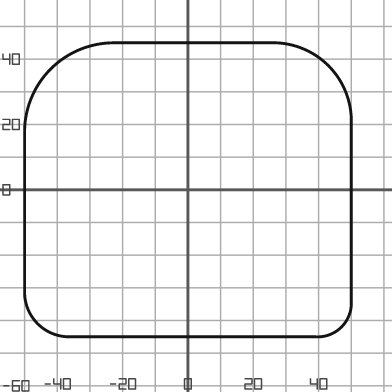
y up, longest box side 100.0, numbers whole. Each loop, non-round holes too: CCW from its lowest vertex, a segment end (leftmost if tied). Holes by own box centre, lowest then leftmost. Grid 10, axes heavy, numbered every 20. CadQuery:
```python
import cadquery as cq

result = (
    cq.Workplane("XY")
    .moveTo(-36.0, -45.0)
    .lineTo(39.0, -45.0)
    .threePointArc((47.0, -42.0), (50.0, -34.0))
    .lineTo(50.0, 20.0)
    .threePointArc((43.0, 38.0), (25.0, 45.0))
    .lineTo(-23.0, 45.0)
    .threePointArc((-42.0, 37.0), (-50.0, 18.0))
    .lineTo(-50.0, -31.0)
    .threePointArc((-46.0, -41.0), (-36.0, -45.0))
    .close()
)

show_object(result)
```